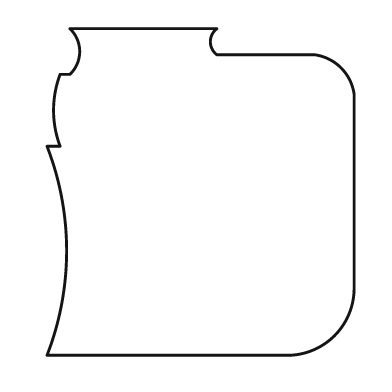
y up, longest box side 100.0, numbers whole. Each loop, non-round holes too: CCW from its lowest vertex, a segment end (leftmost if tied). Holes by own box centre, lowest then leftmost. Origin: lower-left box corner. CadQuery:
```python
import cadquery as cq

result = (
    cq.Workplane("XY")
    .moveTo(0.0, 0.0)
    .lineTo(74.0, 0.0)
    .threePointArc((88.0, 6.0), (94.0, 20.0))
    .lineTo(94.0, 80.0)
    .threePointArc((90.0, 88.0), (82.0, 92.0))
    .lineTo(52.0, 92.0)
    .threePointArc((50.0, 96.0), (52.0, 100.0))
    .lineTo(7.0, 100.0)
    .threePointArc((10.0, 93.0), (7.0, 86.0))
    .lineTo(4.0, 86.0)
    .threePointArc((2.0, 75.0), (4.0, 64.0))
    .lineTo(0.0, 64.0)
    .threePointArc((6.0, 32.0), (0.0, 0.0))
    .close()
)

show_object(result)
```